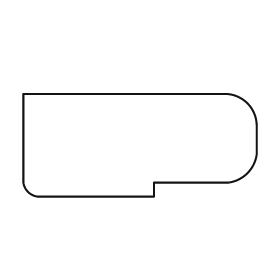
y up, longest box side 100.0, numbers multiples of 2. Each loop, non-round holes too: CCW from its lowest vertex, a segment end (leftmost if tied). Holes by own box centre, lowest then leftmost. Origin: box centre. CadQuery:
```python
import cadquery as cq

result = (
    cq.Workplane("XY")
    .moveTo(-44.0, -22.0)
    .lineTo(6.0, -22.0)
    .lineTo(6.0, -16.0)
    .lineTo(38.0, -16.0)
    .threePointArc((46.0, -12.0), (50.0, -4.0))
    .lineTo(50.0, 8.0)
    .threePointArc((46.0, 18.0), (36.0, 22.0))
    .lineTo(-50.0, 22.0)
    .lineTo(-50.0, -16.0)
    .threePointArc((-48.0, -20.0), (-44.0, -22.0))
    .close()
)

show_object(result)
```